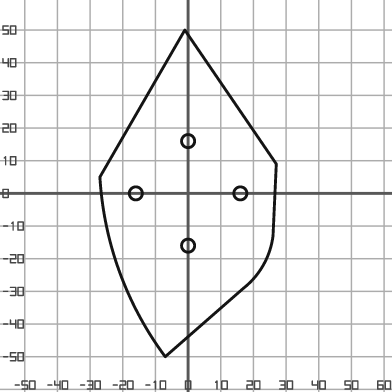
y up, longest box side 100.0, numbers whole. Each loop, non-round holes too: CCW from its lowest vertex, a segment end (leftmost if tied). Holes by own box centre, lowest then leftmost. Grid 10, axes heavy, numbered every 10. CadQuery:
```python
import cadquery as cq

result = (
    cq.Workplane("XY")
    .moveTo(-7.0, -50.0)
    .lineTo(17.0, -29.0)
    .threePointArc((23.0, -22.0), (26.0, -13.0))
    .lineTo(27.0, 9.0)
    .lineTo(-1.0, 50.0)
    .lineTo(-27.0, 5.0)
    .threePointArc((-21.0, -24.0), (-7.0, -50.0))
    .close()
    .moveTo(0.0, -16.0)
    .circle(2.0)
    .moveTo(-16.0, 0.0)
    .circle(2.0)
    .moveTo(16.0, 0.0)
    .circle(2.0)
    .moveTo(0.0, 16.0)
    .circle(2.0)
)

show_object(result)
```